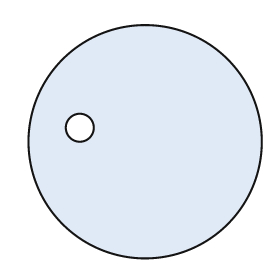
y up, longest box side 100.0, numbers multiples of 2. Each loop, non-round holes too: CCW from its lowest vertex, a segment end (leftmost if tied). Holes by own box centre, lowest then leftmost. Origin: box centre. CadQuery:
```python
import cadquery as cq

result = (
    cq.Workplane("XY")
    .moveTo(0.0, 0.0)
    .circle(50.0)
    .moveTo(-28.0, 6.0)
    .circle(6.0)
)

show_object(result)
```